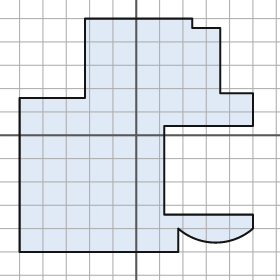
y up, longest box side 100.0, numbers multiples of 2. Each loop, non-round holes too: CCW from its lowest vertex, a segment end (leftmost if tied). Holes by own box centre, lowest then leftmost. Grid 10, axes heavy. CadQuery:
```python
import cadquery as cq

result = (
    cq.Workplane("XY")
    .moveTo(-50.0, -50.0)
    .lineTo(18.0, -50.0)
    .lineTo(18.0, -40.0)
    .threePointArc((34.0, -46.0), (50.0, -40.0))
    .lineTo(50.0, -34.0)
    .lineTo(12.0, -34.0)
    .lineTo(12.0, 4.0)
    .lineTo(50.0, 4.0)
    .lineTo(50.0, 18.0)
    .lineTo(36.0, 18.0)
    .lineTo(36.0, 46.0)
    .lineTo(24.0, 46.0)
    .lineTo(24.0, 50.0)
    .lineTo(-22.0, 50.0)
    .lineTo(-22.0, 16.0)
    .lineTo(-50.0, 16.0)
    .close()
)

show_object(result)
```